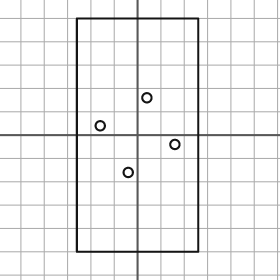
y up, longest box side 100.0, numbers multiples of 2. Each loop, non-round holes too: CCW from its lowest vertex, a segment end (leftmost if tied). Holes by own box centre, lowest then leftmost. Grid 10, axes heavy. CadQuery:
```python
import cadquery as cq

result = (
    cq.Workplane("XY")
    .moveTo(-26.0, -50.0)
    .lineTo(26.0, -50.0)
    .lineTo(26.0, 50.0)
    .lineTo(-26.0, 50.0)
    .close()
    .moveTo(-4.0, -16.0)
    .circle(2.0)
    .moveTo(16.0, -4.0)
    .circle(2.0)
    .moveTo(-16.0, 4.0)
    .circle(2.0)
    .moveTo(4.0, 16.0)
    .circle(2.0)
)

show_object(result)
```